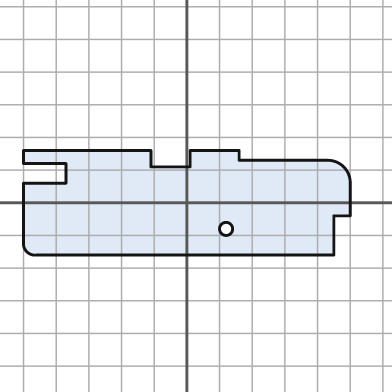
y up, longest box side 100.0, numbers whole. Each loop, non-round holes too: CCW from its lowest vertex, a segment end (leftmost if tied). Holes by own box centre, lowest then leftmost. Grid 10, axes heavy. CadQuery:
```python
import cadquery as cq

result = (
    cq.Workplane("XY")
    .moveTo(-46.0, -16.0)
    .lineTo(45.0, -16.0)
    .lineTo(45.0, -4.0)
    .lineTo(50.0, -4.0)
    .lineTo(50.0, 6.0)
    .threePointArc((48.0, 11.0), (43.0, 13.0))
    .lineTo(16.0, 13.0)
    .lineTo(16.0, 16.0)
    .lineTo(1.0, 16.0)
    .lineTo(1.0, 11.0)
    .lineTo(-11.0, 11.0)
    .lineTo(-11.0, 16.0)
    .lineTo(-50.0, 16.0)
    .lineTo(-50.0, 12.0)
    .lineTo(-37.0, 12.0)
    .lineTo(-37.0, 6.0)
    .lineTo(-50.0, 6.0)
    .lineTo(-50.0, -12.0)
    .threePointArc((-49.0, -15.0), (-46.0, -16.0))
    .close()
    .moveTo(12.0, -8.0)
    .circle(2.0)
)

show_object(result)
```